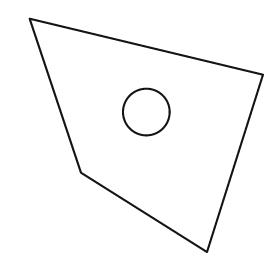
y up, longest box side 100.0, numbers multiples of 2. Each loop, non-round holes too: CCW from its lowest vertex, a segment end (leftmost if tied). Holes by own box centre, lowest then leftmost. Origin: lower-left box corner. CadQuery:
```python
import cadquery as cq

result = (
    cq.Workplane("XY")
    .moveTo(76.0, 0.0)
    .lineTo(100.0, 76.0)
    .lineTo(0.0, 100.0)
    .lineTo(22.0, 34.0)
    .close()
    .moveTo(50.0, 60.0)
    .circle(10.0)
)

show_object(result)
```